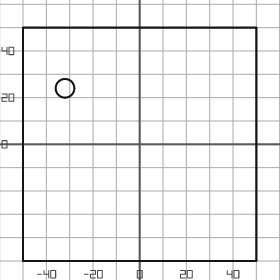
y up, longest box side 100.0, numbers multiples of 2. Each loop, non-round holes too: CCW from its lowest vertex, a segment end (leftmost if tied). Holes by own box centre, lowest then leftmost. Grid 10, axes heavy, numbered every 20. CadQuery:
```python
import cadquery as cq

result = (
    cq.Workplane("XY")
    .moveTo(-50.0, -50.0)
    .lineTo(50.0, -50.0)
    .lineTo(50.0, 50.0)
    .lineTo(-50.0, 50.0)
    .close()
    .moveTo(-32.0, 24.0)
    .circle(4.0)
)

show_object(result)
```